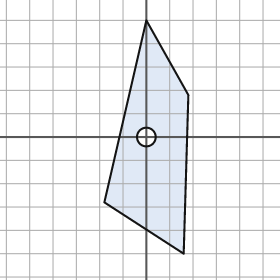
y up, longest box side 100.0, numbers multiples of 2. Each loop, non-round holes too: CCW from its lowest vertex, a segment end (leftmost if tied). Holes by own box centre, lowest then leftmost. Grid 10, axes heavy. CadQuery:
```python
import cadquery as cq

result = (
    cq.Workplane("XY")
    .moveTo(16.0, -50.0)
    .lineTo(18.0, 18.0)
    .lineTo(0.0, 50.0)
    .lineTo(-18.0, -28.0)
    .close()
    .moveTo(0.0, 0.0)
    .circle(4.0)
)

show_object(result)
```